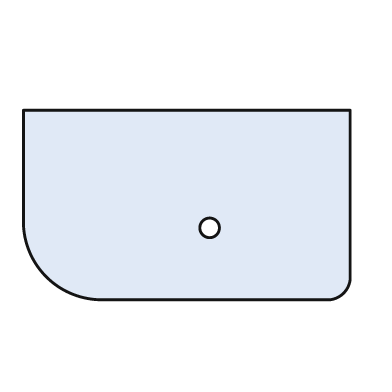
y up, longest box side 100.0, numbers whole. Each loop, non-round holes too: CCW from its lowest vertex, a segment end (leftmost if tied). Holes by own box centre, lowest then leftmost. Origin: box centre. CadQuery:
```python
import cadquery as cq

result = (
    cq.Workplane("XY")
    .moveTo(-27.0, -29.0)
    .lineTo(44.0, -29.0)
    .threePointArc((48.0, -27.0), (50.0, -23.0))
    .lineTo(50.0, 29.0)
    .lineTo(-50.0, 29.0)
    .lineTo(-50.0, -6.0)
    .threePointArc((-43.0, -22.0), (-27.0, -29.0))
    .close()
    .moveTo(7.0, -7.0)
    .circle(3.0)
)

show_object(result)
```